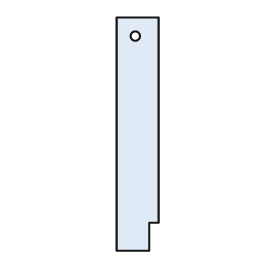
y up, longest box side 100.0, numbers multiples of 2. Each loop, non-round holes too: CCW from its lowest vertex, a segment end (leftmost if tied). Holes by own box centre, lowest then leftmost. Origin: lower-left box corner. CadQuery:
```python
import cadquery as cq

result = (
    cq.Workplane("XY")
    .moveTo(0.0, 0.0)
    .lineTo(14.0, 0.0)
    .lineTo(14.0, 12.0)
    .lineTo(18.0, 12.0)
    .lineTo(18.0, 100.0)
    .lineTo(0.0, 100.0)
    .close()
    .moveTo(8.0, 92.0)
    .circle(2.0)
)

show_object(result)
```